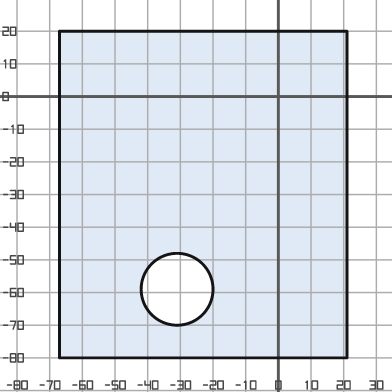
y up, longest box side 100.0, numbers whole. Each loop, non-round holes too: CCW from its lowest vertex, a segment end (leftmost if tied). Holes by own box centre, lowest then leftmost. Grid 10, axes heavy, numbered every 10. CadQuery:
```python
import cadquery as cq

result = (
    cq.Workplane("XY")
    .moveTo(-67.0, -80.0)
    .lineTo(21.0, -80.0)
    .lineTo(21.0, 20.0)
    .lineTo(-67.0, 20.0)
    .close()
    .moveTo(-31.0, -59.0)
    .circle(11.0)
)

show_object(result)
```